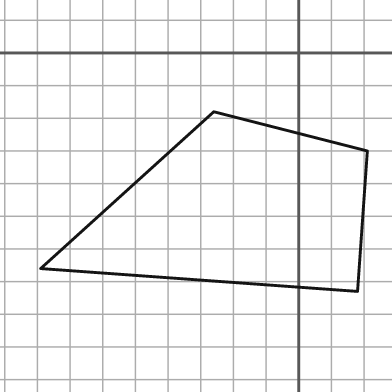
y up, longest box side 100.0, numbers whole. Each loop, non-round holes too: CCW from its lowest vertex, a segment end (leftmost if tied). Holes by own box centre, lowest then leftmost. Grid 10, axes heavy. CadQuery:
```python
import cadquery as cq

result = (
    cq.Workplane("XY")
    .moveTo(18.0, -73.0)
    .lineTo(21.0, -30.0)
    .lineTo(-26.0, -18.0)
    .lineTo(-79.0, -66.0)
    .close()
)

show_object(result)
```